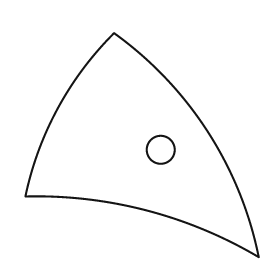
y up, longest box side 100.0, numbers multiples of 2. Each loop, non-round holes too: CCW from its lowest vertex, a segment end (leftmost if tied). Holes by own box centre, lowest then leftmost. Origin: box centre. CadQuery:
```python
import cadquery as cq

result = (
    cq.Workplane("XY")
    .moveTo(50.0, -48.0)
    .threePointArc((28.0, 6.0), (-12.0, 48.0))
    .threePointArc((-36.0, 16.0), (-50.0, -22.0))
    .threePointArc((2.0, -28.0), (50.0, -48.0))
    .close()
    .moveTo(8.0, -2.0)
    .circle(6.0)
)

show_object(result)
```